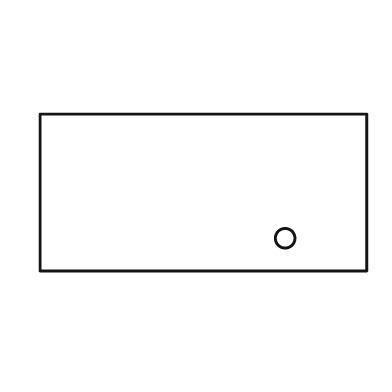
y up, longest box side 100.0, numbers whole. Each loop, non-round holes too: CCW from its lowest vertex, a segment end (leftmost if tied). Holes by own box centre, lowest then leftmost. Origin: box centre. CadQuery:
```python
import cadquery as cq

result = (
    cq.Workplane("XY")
    .moveTo(-50.0, -24.0)
    .lineTo(50.0, -24.0)
    .lineTo(50.0, 24.0)
    .lineTo(-50.0, 24.0)
    .close()
    .moveTo(25.0, -14.0)
    .circle(3.0)
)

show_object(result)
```